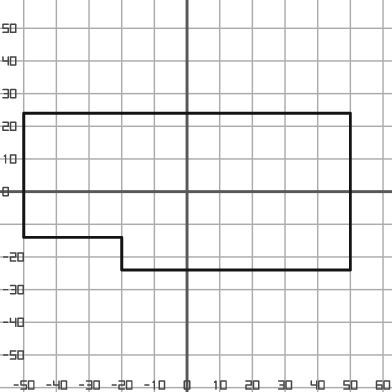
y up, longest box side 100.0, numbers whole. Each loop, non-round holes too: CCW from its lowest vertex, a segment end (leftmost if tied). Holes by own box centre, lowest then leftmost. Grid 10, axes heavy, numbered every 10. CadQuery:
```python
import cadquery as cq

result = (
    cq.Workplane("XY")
    .moveTo(-20.0, -24.0)
    .lineTo(50.0, -24.0)
    .lineTo(50.0, 24.0)
    .lineTo(-50.0, 24.0)
    .lineTo(-50.0, -14.0)
    .lineTo(-20.0, -14.0)
    .close()
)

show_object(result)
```